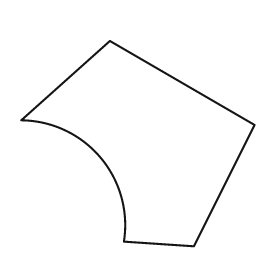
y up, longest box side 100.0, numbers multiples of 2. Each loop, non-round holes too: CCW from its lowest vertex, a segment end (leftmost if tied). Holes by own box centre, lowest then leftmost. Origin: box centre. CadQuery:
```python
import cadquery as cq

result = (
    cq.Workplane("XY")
    .moveTo(24.0, -44.0)
    .lineTo(50.0, 8.0)
    .lineTo(-12.0, 44.0)
    .lineTo(-50.0, 10.0)
    .threePointArc((-16.0, -6.0), (-6.0, -42.0))
    .close()
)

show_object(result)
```